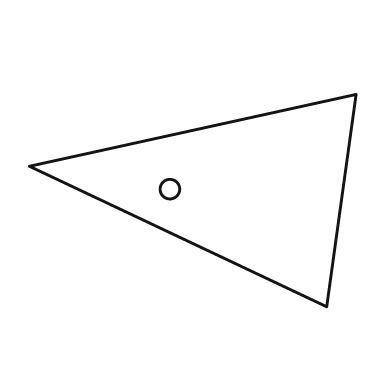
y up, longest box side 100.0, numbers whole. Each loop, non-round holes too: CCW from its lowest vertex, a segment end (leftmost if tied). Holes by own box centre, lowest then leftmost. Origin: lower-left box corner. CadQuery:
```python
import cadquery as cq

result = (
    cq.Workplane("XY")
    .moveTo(91.0, 0.0)
    .lineTo(100.0, 65.0)
    .lineTo(0.0, 43.0)
    .close()
    .moveTo(43.0, 36.0)
    .circle(3.0)
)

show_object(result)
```